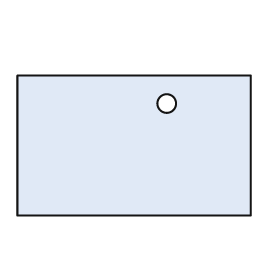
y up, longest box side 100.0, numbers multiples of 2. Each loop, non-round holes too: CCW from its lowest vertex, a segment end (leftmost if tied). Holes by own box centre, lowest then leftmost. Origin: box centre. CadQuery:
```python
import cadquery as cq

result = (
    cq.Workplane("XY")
    .moveTo(-50.0, -30.0)
    .lineTo(50.0, -30.0)
    .lineTo(50.0, 30.0)
    .lineTo(-50.0, 30.0)
    .close()
    .moveTo(14.0, 18.0)
    .circle(4.0)
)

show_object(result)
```